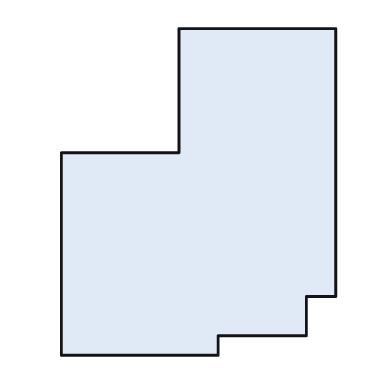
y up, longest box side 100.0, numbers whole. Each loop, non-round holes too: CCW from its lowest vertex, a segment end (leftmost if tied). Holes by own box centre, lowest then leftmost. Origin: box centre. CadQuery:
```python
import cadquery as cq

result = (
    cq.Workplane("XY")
    .moveTo(-42.0, -50.0)
    .lineTo(6.0, -50.0)
    .lineTo(6.0, -44.0)
    .lineTo(33.0, -44.0)
    .lineTo(33.0, -32.0)
    .lineTo(42.0, -32.0)
    .lineTo(42.0, 50.0)
    .lineTo(-6.0, 50.0)
    .lineTo(-6.0, 12.0)
    .lineTo(-42.0, 12.0)
    .close()
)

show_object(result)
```